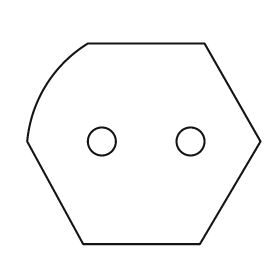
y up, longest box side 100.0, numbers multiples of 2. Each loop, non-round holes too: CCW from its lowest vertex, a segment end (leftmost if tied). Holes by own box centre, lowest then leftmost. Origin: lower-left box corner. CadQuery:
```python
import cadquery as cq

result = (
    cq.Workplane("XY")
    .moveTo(24.0, 0.0)
    .lineTo(74.0, 0.0)
    .lineTo(100.0, 44.0)
    .lineTo(76.0, 86.0)
    .lineTo(26.0, 86.0)
    .threePointArc((8.0, 68.0), (0.0, 44.0))
    .close()
    .moveTo(32.0, 44.0)
    .circle(6.0)
    .moveTo(70.0, 44.0)
    .circle(6.0)
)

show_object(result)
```